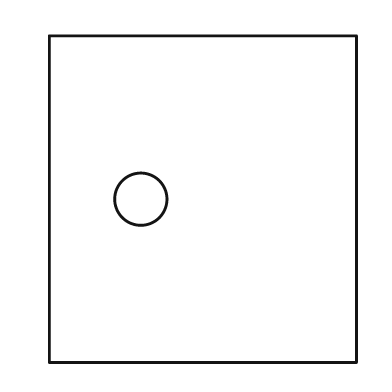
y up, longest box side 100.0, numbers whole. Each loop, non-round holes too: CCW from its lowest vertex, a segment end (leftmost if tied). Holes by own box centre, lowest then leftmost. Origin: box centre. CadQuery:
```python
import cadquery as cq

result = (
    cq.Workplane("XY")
    .moveTo(-47.0, -50.0)
    .lineTo(47.0, -50.0)
    .lineTo(47.0, 50.0)
    .lineTo(-47.0, 50.0)
    .close()
    .moveTo(-19.0, 0.0)
    .circle(8.0)
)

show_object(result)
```